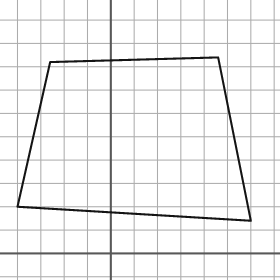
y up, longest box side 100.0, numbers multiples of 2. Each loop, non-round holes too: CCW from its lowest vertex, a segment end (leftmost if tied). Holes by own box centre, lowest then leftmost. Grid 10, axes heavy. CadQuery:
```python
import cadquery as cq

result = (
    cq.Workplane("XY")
    .moveTo(60.0, 14.0)
    .lineTo(46.0, 84.0)
    .lineTo(-26.0, 82.0)
    .lineTo(-40.0, 20.0)
    .close()
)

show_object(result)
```